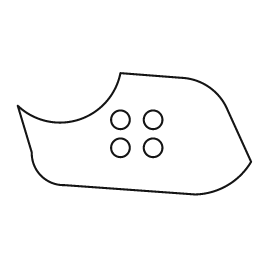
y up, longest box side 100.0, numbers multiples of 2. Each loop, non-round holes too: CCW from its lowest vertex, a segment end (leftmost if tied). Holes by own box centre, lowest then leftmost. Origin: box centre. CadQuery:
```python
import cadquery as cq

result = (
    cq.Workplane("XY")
    .moveTo(26.0, -26.0)
    .threePointArc((40.0, -22.0), (50.0, -12.0))
    .lineTo(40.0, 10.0)
    .threePointArc((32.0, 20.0), (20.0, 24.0))
    .lineTo(-6.0, 26.0)
    .threePointArc((-24.0, 6.0), (-50.0, 12.0))
    .lineTo(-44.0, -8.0)
    .threePointArc((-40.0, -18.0), (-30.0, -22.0))
    .close()
    .moveTo(-6.0, -6.0)
    .circle(4.0)
    .moveTo(8.0, -6.0)
    .circle(4.0)
    .moveTo(-6.0, 6.0)
    .circle(4.0)
    .moveTo(8.0, 6.0)
    .circle(4.0)
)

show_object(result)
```